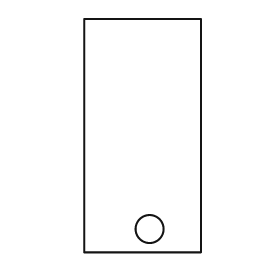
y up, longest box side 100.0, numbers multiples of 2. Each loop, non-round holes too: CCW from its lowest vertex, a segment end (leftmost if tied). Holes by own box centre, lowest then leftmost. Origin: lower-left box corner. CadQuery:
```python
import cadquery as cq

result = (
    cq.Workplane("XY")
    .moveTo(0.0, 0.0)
    .lineTo(50.0, 0.0)
    .lineTo(50.0, 100.0)
    .lineTo(0.0, 100.0)
    .close()
    .moveTo(28.0, 10.0)
    .circle(6.0)
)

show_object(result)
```